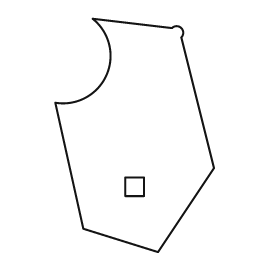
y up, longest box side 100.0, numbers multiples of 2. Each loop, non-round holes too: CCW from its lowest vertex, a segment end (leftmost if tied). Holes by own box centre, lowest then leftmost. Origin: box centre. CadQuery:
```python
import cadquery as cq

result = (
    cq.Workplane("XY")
    .moveTo(10.0, -50.0)
    .lineTo(34.0, -14.0)
    .lineTo(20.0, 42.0)
    .threePointArc((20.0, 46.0), (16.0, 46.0))
    .lineTo(-18.0, 50.0)
    .threePointArc((-12.0, 26.0), (-34.0, 14.0))
    .lineTo(-22.0, -40.0)
    .close()
    .moveTo(-4.0, -26.0)
    .lineTo(4.0, -26.0)
    .lineTo(4.0, -18.0)
    .lineTo(-4.0, -18.0)
    .close()
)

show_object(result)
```